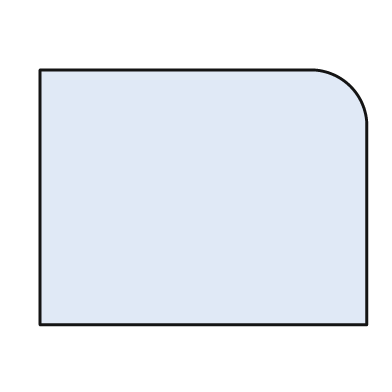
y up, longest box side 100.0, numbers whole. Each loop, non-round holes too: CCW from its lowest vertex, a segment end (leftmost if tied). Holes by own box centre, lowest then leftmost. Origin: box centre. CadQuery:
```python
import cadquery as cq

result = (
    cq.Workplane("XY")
    .moveTo(-50.0, -39.0)
    .lineTo(50.0, -39.0)
    .lineTo(50.0, 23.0)
    .threePointArc((45.0, 34.0), (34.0, 39.0))
    .lineTo(-50.0, 39.0)
    .close()
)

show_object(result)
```